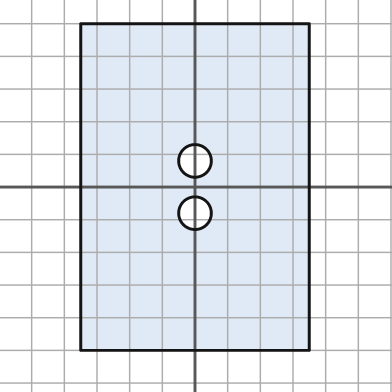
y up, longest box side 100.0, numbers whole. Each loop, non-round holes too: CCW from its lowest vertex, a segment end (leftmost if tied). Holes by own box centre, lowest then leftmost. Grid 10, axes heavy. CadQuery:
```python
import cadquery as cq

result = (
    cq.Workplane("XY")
    .moveTo(-35.0, -50.0)
    .lineTo(35.0, -50.0)
    .lineTo(35.0, 50.0)
    .lineTo(-35.0, 50.0)
    .close()
    .moveTo(0.0, -8.0)
    .circle(5.0)
    .moveTo(0.0, 8.0)
    .circle(5.0)
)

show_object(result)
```